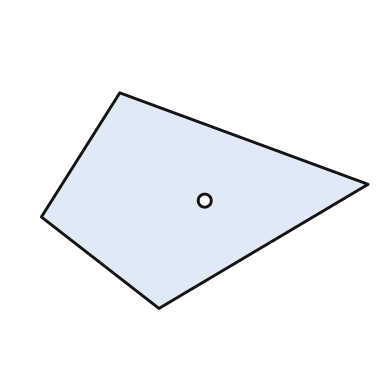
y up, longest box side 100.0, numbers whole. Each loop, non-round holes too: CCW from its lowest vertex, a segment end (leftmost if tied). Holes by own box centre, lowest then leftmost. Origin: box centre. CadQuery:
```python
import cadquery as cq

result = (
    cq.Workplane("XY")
    .moveTo(-14.0, -33.0)
    .lineTo(50.0, 5.0)
    .lineTo(-26.0, 33.0)
    .lineTo(-50.0, -5.0)
    .close()
    .moveTo(0.0, 0.0)
    .circle(2.0)
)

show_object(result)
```